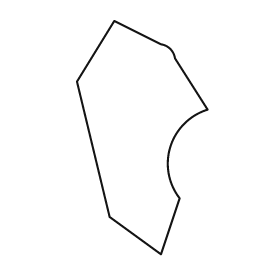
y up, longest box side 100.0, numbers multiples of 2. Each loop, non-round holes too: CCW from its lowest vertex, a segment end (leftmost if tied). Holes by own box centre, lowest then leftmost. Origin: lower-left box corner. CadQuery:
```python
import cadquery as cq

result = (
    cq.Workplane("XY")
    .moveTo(36.0, 0.0)
    .lineTo(44.0, 24.0)
    .threePointArc((40.0, 46.0), (56.0, 62.0))
    .lineTo(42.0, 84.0)
    .threePointArc((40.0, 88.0), (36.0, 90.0))
    .lineTo(16.0, 100.0)
    .lineTo(0.0, 74.0)
    .lineTo(14.0, 16.0)
    .close()
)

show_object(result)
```